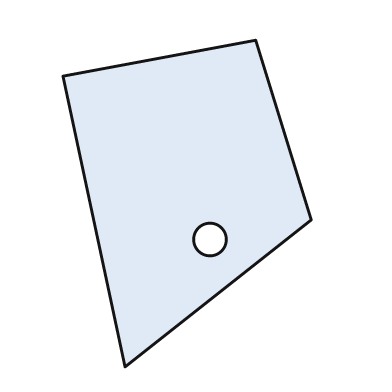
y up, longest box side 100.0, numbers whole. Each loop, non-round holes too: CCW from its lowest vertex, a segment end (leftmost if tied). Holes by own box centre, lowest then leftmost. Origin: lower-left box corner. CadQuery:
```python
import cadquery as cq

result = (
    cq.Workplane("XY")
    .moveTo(19.0, 0.0)
    .lineTo(76.0, 45.0)
    .lineTo(59.0, 100.0)
    .lineTo(0.0, 89.0)
    .close()
    .moveTo(45.0, 39.0)
    .circle(5.0)
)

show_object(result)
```